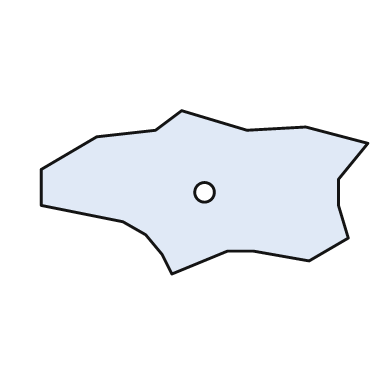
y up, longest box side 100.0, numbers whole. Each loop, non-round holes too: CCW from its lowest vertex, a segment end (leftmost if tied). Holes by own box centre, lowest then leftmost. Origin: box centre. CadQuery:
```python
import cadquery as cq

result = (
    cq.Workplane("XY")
    .moveTo(-10.0, -25.0)
    .lineTo(7.0, -18.0)
    .lineTo(15.0, -18.0)
    .lineTo(32.0, -21.0)
    .lineTo(44.0, -14.0)
    .lineTo(41.0, -4.0)
    .lineTo(41.0, 4.0)
    .lineTo(50.0, 15.0)
    .lineTo(31.0, 20.0)
    .lineTo(13.0, 19.0)
    .lineTo(-7.0, 25.0)
    .lineTo(-15.0, 19.0)
    .lineTo(-33.0, 17.0)
    .lineTo(-50.0, 7.0)
    .lineTo(-50.0, -4.0)
    .lineTo(-25.0, -9.0)
    .lineTo(-18.0, -13.0)
    .lineTo(-13.0, -19.0)
    .close()
    .moveTo(0.0, 0.0)
    .circle(3.0)
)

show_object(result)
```